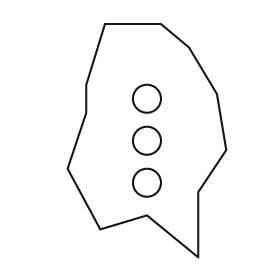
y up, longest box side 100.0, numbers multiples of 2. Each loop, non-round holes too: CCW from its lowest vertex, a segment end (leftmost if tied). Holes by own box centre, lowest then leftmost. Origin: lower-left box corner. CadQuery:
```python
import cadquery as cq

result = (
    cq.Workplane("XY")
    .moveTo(56.0, 0.0)
    .lineTo(56.0, 28.0)
    .lineTo(68.0, 46.0)
    .lineTo(64.0, 70.0)
    .lineTo(52.0, 90.0)
    .lineTo(40.0, 100.0)
    .lineTo(16.0, 100.0)
    .lineTo(8.0, 74.0)
    .lineTo(8.0, 62.0)
    .lineTo(0.0, 38.0)
    .lineTo(14.0, 12.0)
    .lineTo(34.0, 18.0)
    .close()
    .moveTo(34.0, 32.0)
    .circle(6.0)
    .moveTo(34.0, 50.0)
    .circle(6.0)
    .moveTo(34.0, 68.0)
    .circle(6.0)
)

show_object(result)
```